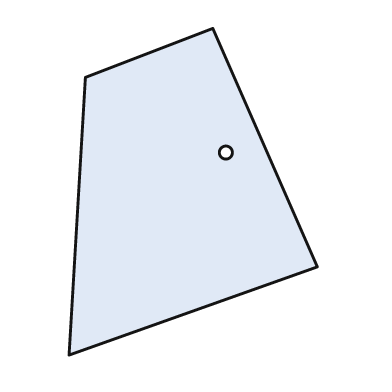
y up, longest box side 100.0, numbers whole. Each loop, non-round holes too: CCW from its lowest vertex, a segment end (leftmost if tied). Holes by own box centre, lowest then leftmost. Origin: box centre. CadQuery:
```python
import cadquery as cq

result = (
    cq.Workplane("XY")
    .moveTo(-38.0, -50.0)
    .lineTo(38.0, -23.0)
    .lineTo(6.0, 50.0)
    .lineTo(-33.0, 35.0)
    .close()
    .moveTo(10.0, 12.0)
    .circle(2.0)
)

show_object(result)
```